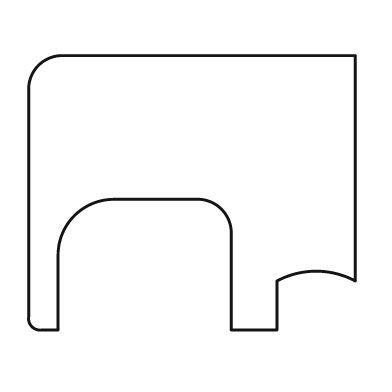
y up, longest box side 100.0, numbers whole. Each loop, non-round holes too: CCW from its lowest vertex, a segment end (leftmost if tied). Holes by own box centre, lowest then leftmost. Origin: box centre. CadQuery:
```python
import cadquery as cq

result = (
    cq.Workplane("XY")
    .moveTo(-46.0, -42.0)
    .lineTo(-41.0, -42.0)
    .lineTo(-41.0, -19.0)
    .threePointArc((-36.0, -7.0), (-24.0, -2.0))
    .lineTo(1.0, -2.0)
    .threePointArc((9.0, -5.0), (12.0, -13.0))
    .lineTo(12.0, -42.0)
    .lineTo(26.0, -42.0)
    .lineTo(26.0, -27.0)
    .threePointArc((38.0, -24.0), (50.0, -27.0))
    .lineTo(50.0, 42.0)
    .lineTo(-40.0, 42.0)
    .threePointArc((-47.0, 39.0), (-50.0, 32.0))
    .lineTo(-50.0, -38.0)
    .threePointArc((-49.0, -41.0), (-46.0, -42.0))
    .close()
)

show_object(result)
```